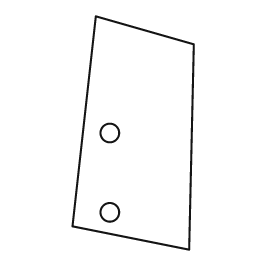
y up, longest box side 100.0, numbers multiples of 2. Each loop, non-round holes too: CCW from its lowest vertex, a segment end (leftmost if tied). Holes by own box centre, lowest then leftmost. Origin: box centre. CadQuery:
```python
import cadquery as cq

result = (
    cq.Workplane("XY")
    .moveTo(24.0, -50.0)
    .lineTo(26.0, 38.0)
    .lineTo(-16.0, 50.0)
    .lineTo(-26.0, -40.0)
    .close()
    .moveTo(-10.0, -34.0)
    .circle(4.0)
    .moveTo(-10.0, 0.0)
    .circle(4.0)
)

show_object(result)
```